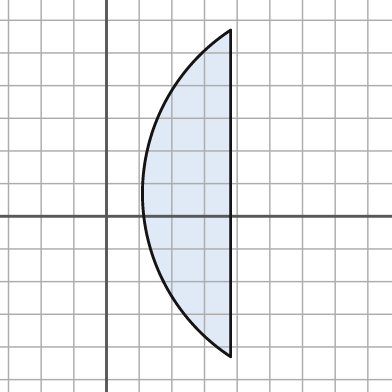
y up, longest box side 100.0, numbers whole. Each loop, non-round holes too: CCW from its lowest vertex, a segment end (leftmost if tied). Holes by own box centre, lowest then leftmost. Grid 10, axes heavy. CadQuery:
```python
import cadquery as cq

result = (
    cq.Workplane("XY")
    .moveTo(38.0, -43.0)
    .lineTo(38.0, 57.0)
    .threePointArc((11.0, 7.0), (38.0, -43.0))
    .close()
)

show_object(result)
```